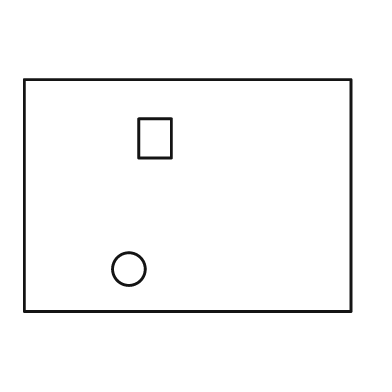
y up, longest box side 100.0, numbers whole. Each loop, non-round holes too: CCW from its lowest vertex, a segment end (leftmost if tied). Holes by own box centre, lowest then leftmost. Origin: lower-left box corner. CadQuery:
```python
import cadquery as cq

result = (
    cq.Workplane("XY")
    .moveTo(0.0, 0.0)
    .lineTo(100.0, 0.0)
    .lineTo(100.0, 71.0)
    .lineTo(0.0, 71.0)
    .close()
    .moveTo(32.0, 13.0)
    .circle(5.0)
    .moveTo(35.0, 47.0)
    .lineTo(45.0, 47.0)
    .lineTo(45.0, 59.0)
    .lineTo(35.0, 59.0)
    .close()
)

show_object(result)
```